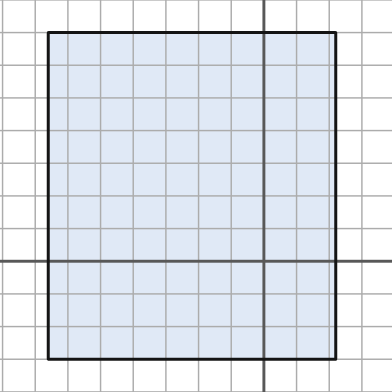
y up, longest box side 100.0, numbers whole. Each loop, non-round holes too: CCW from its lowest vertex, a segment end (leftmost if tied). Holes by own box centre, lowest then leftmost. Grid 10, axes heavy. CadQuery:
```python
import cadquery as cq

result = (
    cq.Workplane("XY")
    .moveTo(-66.0, -30.0)
    .lineTo(22.0, -30.0)
    .lineTo(22.0, 70.0)
    .lineTo(-66.0, 70.0)
    .close()
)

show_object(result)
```